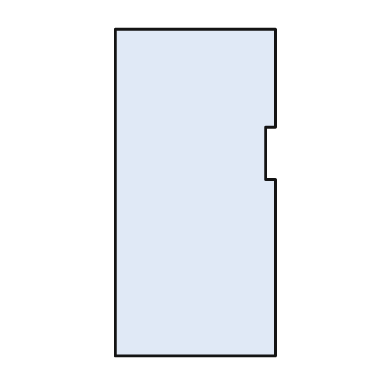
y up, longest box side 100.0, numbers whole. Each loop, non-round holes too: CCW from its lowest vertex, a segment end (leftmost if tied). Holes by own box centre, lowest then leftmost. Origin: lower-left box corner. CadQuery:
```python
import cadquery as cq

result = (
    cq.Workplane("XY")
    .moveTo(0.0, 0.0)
    .lineTo(49.0, 0.0)
    .lineTo(49.0, 54.0)
    .lineTo(46.0, 54.0)
    .lineTo(46.0, 70.0)
    .lineTo(49.0, 70.0)
    .lineTo(49.0, 100.0)
    .lineTo(0.0, 100.0)
    .close()
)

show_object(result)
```